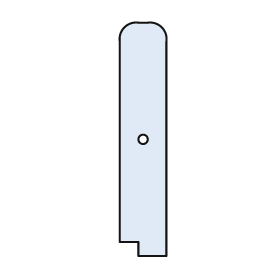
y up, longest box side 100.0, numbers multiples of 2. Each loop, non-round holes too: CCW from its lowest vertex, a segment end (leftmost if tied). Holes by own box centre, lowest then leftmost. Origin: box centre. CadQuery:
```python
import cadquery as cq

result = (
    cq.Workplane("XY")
    .moveTo(-2.0, -50.0)
    .lineTo(10.0, -50.0)
    .lineTo(10.0, 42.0)
    .threePointArc((8.0, 48.0), (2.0, 50.0))
    .lineTo(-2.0, 50.0)
    .threePointArc((-8.0, 48.0), (-10.0, 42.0))
    .lineTo(-10.0, -44.0)
    .lineTo(-2.0, -44.0)
    .close()
    .moveTo(0.0, 0.0)
    .circle(2.0)
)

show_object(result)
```